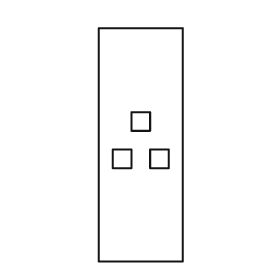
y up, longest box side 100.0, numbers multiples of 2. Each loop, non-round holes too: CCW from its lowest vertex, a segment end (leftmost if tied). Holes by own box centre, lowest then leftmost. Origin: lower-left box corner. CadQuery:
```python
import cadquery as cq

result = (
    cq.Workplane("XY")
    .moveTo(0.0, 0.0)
    .lineTo(36.0, 0.0)
    .lineTo(36.0, 100.0)
    .lineTo(0.0, 100.0)
    .close()
    .moveTo(6.0, 40.0)
    .lineTo(14.0, 40.0)
    .lineTo(14.0, 48.0)
    .lineTo(6.0, 48.0)
    .close()
    .moveTo(22.0, 40.0)
    .lineTo(30.0, 40.0)
    .lineTo(30.0, 48.0)
    .lineTo(22.0, 48.0)
    .close()
    .moveTo(14.0, 56.0)
    .lineTo(22.0, 56.0)
    .lineTo(22.0, 64.0)
    .lineTo(14.0, 64.0)
    .close()
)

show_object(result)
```